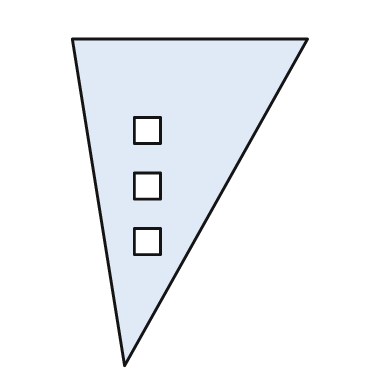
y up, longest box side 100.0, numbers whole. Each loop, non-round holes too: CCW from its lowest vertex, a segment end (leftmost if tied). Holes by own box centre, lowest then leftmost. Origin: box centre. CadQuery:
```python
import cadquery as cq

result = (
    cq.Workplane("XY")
    .moveTo(-20.0, -50.0)
    .lineTo(36.0, 50.0)
    .lineTo(-36.0, 50.0)
    .close()
    .moveTo(-17.0, -16.0)
    .lineTo(-9.0, -16.0)
    .lineTo(-9.0, -8.0)
    .lineTo(-17.0, -8.0)
    .close()
    .moveTo(-17.0, 1.0)
    .lineTo(-9.0, 1.0)
    .lineTo(-9.0, 9.0)
    .lineTo(-17.0, 9.0)
    .close()
    .moveTo(-17.0, 18.0)
    .lineTo(-9.0, 18.0)
    .lineTo(-9.0, 26.0)
    .lineTo(-17.0, 26.0)
    .close()
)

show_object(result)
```